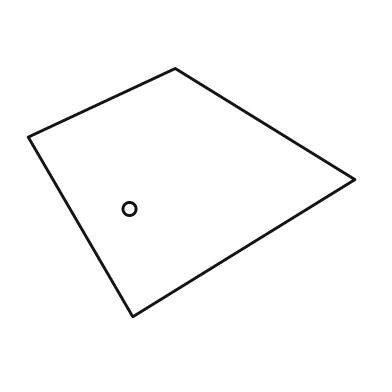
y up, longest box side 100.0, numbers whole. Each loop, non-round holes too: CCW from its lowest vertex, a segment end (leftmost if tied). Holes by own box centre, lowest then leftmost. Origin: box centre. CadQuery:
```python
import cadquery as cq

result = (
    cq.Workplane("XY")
    .moveTo(-18.0, -38.0)
    .lineTo(50.0, 4.0)
    .lineTo(-5.0, 38.0)
    .lineTo(-50.0, 17.0)
    .close()
    .moveTo(-19.0, -5.0)
    .circle(2.0)
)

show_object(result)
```